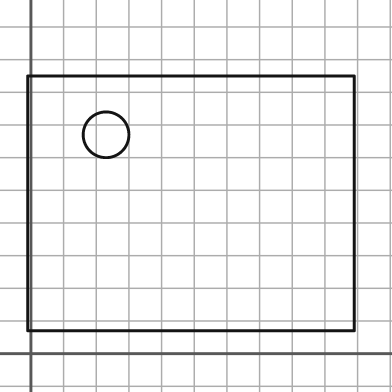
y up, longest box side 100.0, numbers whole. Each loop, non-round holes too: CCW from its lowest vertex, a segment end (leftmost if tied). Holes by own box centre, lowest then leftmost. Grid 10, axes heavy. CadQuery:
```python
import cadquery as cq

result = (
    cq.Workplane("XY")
    .moveTo(-1.0, 7.0)
    .lineTo(99.0, 7.0)
    .lineTo(99.0, 85.0)
    .lineTo(-1.0, 85.0)
    .close()
    .moveTo(23.0, 67.0)
    .circle(7.0)
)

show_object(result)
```